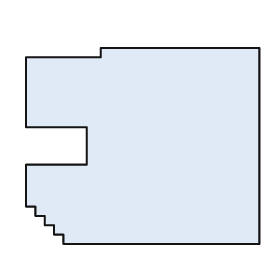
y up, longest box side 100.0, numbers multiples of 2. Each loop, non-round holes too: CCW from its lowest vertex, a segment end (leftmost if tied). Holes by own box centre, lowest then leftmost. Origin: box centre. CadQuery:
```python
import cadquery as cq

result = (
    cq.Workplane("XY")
    .moveTo(-34.0, -42.0)
    .lineTo(50.0, -42.0)
    .lineTo(50.0, 42.0)
    .lineTo(-18.0, 42.0)
    .lineTo(-18.0, 38.0)
    .lineTo(-50.0, 38.0)
    .lineTo(-50.0, 8.0)
    .lineTo(-24.0, 8.0)
    .lineTo(-24.0, -8.0)
    .lineTo(-50.0, -8.0)
    .lineTo(-50.0, -26.0)
    .lineTo(-46.0, -26.0)
    .lineTo(-46.0, -30.0)
    .lineTo(-42.0, -30.0)
    .lineTo(-42.0, -34.0)
    .lineTo(-38.0, -34.0)
    .lineTo(-38.0, -38.0)
    .lineTo(-34.0, -38.0)
    .close()
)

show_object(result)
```